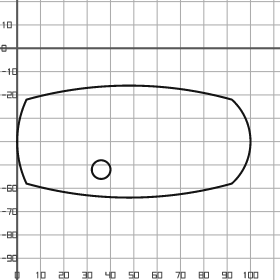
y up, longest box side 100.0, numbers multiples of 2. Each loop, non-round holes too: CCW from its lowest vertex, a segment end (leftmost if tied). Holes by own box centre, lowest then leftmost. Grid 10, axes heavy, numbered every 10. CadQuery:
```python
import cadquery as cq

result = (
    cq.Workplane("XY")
    .moveTo(4.0, -58.0)
    .threePointArc((48.0, -64.0), (92.0, -58.0))
    .threePointArc((100.0, -40.0), (92.0, -22.0))
    .threePointArc((48.0, -16.0), (4.0, -22.0))
    .threePointArc((0.0, -40.0), (4.0, -58.0))
    .close()
    .moveTo(36.0, -52.0)
    .circle(4.0)
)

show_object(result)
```